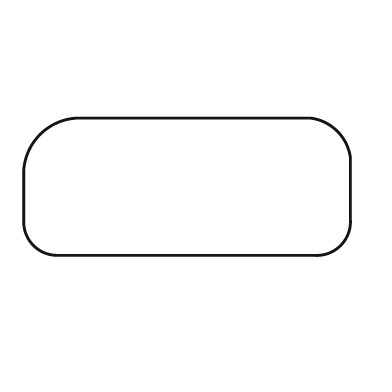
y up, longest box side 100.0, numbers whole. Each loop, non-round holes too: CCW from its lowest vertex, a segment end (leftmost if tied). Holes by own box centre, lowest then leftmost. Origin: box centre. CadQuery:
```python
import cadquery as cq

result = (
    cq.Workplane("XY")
    .moveTo(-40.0, -21.0)
    .lineTo(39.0, -21.0)
    .threePointArc((47.0, -18.0), (50.0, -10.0))
    .lineTo(50.0, 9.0)
    .threePointArc((46.0, 17.0), (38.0, 21.0))
    .lineTo(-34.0, 21.0)
    .threePointArc((-45.0, 16.0), (-50.0, 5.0))
    .lineTo(-50.0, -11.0)
    .threePointArc((-47.0, -18.0), (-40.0, -21.0))
    .close()
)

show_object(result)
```